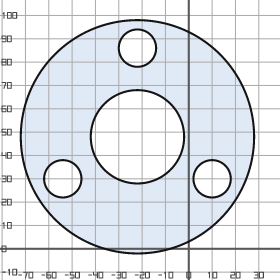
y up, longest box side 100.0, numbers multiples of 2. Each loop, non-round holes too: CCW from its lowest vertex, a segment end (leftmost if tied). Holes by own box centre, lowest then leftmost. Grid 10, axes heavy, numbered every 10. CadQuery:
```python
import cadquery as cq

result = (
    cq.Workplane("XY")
    .moveTo(-22.0, 48.0)
    .circle(50.0)
    .moveTo(-54.0, 30.0)
    .circle(8.0)
    .moveTo(10.0, 30.0)
    .circle(8.0)
    .moveTo(-22.0, 48.0)
    .circle(20.0)
    .moveTo(-22.0, 86.0)
    .circle(8.0)
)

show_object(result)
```